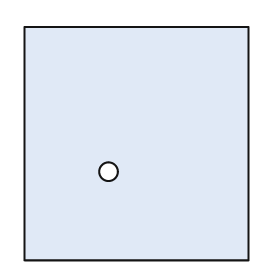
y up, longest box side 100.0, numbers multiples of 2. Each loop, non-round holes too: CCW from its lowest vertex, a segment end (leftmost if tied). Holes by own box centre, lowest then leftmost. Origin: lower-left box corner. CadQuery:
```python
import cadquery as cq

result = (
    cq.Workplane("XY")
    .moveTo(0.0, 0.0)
    .lineTo(96.0, 0.0)
    .lineTo(96.0, 100.0)
    .lineTo(0.0, 100.0)
    .close()
    .moveTo(36.0, 38.0)
    .circle(4.0)
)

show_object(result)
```